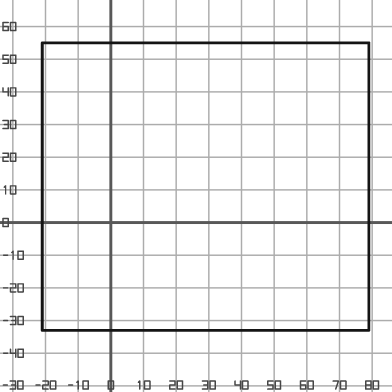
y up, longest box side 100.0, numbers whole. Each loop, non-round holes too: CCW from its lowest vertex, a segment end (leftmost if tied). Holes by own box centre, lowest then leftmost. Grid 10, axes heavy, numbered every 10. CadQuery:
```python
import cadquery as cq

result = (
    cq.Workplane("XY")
    .moveTo(-21.0, -33.0)
    .lineTo(79.0, -33.0)
    .lineTo(79.0, 55.0)
    .lineTo(-21.0, 55.0)
    .close()
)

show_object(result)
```